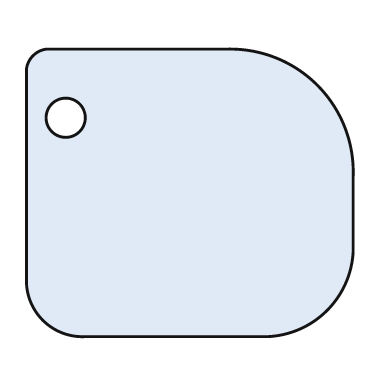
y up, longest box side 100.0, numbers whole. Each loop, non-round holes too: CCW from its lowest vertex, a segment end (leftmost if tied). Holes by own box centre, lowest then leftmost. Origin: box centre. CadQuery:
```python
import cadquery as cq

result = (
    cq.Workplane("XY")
    .moveTo(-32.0, -44.0)
    .lineTo(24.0, -44.0)
    .threePointArc((42.0, -36.0), (50.0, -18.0))
    .lineTo(50.0, 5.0)
    .threePointArc((39.0, 33.0), (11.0, 44.0))
    .lineTo(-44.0, 44.0)
    .threePointArc((-48.0, 42.0), (-50.0, 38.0))
    .lineTo(-50.0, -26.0)
    .threePointArc((-45.0, -39.0), (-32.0, -44.0))
    .close()
    .moveTo(-38.0, 23.0)
    .circle(6.0)
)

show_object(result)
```